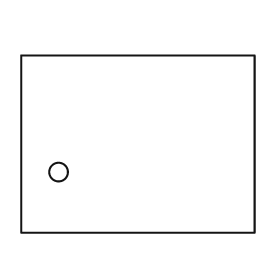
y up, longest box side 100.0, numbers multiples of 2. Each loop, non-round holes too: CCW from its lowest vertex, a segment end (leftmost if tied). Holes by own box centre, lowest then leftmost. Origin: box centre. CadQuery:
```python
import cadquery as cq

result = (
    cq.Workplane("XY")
    .moveTo(-50.0, -38.0)
    .lineTo(50.0, -38.0)
    .lineTo(50.0, 38.0)
    .lineTo(-50.0, 38.0)
    .close()
    .moveTo(-34.0, -12.0)
    .circle(4.0)
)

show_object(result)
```